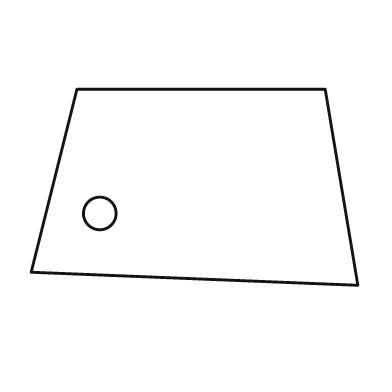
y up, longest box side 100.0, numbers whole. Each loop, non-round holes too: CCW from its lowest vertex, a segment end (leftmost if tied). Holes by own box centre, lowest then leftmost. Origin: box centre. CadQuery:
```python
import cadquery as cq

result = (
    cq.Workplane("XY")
    .moveTo(50.0, -30.0)
    .lineTo(40.0, 30.0)
    .lineTo(-36.0, 30.0)
    .lineTo(-50.0, -26.0)
    .close()
    .moveTo(-29.0, -8.0)
    .circle(5.0)
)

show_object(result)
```